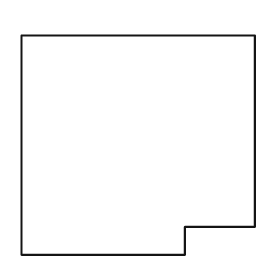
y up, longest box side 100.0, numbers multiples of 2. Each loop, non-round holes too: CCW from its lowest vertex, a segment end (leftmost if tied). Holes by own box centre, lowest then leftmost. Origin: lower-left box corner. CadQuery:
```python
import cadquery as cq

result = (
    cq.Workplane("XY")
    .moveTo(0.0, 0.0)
    .lineTo(70.0, 0.0)
    .lineTo(70.0, 12.0)
    .lineTo(100.0, 12.0)
    .lineTo(100.0, 94.0)
    .lineTo(0.0, 94.0)
    .close()
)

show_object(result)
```